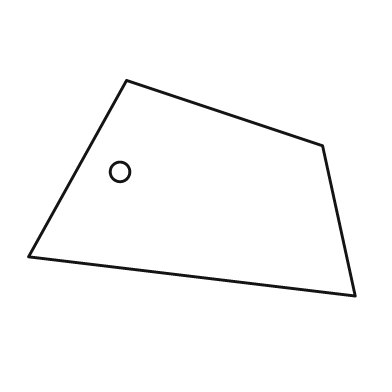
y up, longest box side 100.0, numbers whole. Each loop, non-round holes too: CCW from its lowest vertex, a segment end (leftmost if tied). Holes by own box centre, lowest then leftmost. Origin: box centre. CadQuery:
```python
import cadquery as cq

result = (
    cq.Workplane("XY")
    .moveTo(50.0, -33.0)
    .lineTo(40.0, 13.0)
    .lineTo(-20.0, 33.0)
    .lineTo(-50.0, -21.0)
    .close()
    .moveTo(-22.0, 5.0)
    .circle(3.0)
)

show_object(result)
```